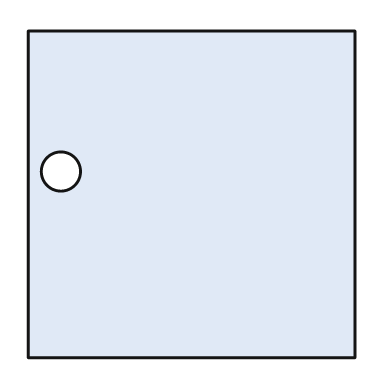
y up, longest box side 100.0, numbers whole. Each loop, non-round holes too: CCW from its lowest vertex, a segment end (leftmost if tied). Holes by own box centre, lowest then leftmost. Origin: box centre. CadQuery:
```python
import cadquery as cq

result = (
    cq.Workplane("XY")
    .moveTo(-50.0, -50.0)
    .lineTo(50.0, -50.0)
    .lineTo(50.0, 50.0)
    .lineTo(-50.0, 50.0)
    .close()
    .moveTo(-40.0, 7.0)
    .circle(6.0)
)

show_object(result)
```